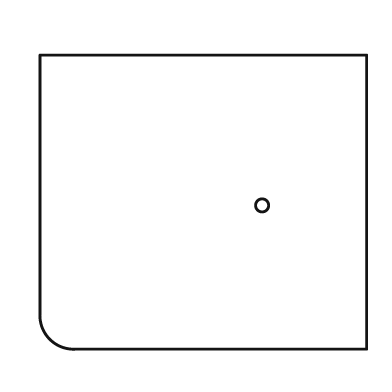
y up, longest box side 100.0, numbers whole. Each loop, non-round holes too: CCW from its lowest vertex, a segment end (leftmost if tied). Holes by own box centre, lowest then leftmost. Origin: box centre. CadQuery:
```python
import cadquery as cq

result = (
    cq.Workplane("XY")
    .moveTo(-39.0, -45.0)
    .lineTo(50.0, -45.0)
    .lineTo(50.0, 45.0)
    .lineTo(-50.0, 45.0)
    .lineTo(-50.0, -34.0)
    .threePointArc((-47.0, -42.0), (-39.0, -45.0))
    .close()
    .moveTo(18.0, -1.0)
    .circle(2.0)
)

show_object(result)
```